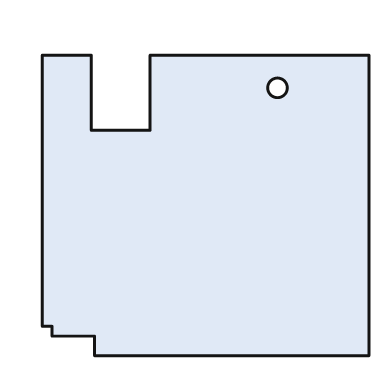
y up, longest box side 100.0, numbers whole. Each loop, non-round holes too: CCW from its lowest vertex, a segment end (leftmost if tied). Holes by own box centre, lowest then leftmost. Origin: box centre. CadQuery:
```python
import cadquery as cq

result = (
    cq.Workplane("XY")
    .moveTo(-34.0, -46.0)
    .lineTo(50.0, -46.0)
    .lineTo(50.0, 46.0)
    .lineTo(-17.0, 46.0)
    .lineTo(-17.0, 23.0)
    .lineTo(-35.0, 23.0)
    .lineTo(-35.0, 46.0)
    .lineTo(-50.0, 46.0)
    .lineTo(-50.0, -37.0)
    .lineTo(-47.0, -37.0)
    .lineTo(-47.0, -40.0)
    .lineTo(-34.0, -40.0)
    .close()
    .moveTo(22.0, 36.0)
    .circle(3.0)
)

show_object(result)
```